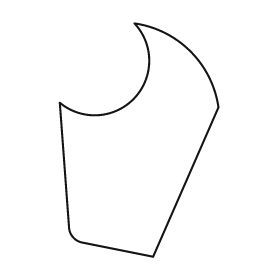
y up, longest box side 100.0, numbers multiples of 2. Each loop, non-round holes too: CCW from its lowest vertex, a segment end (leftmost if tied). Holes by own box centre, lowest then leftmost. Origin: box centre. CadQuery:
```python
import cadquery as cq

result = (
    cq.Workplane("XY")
    .moveTo(6.0, -50.0)
    .lineTo(34.0, 14.0)
    .threePointArc((22.0, 38.0), (-2.0, 50.0))
    .threePointArc((-2.0, 18.0), (-34.0, 16.0))
    .lineTo(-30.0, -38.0)
    .threePointArc((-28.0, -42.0), (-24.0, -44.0))
    .close()
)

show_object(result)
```